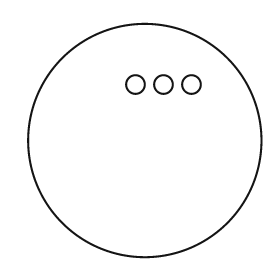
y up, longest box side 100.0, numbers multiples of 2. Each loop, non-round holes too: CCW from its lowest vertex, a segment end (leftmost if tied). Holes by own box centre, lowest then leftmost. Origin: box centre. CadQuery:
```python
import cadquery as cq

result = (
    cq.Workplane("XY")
    .moveTo(0.0, 0.0)
    .circle(50.0)
    .moveTo(-4.0, 24.0)
    .circle(4.0)
    .moveTo(8.0, 24.0)
    .circle(4.0)
    .moveTo(20.0, 24.0)
    .circle(4.0)
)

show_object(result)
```